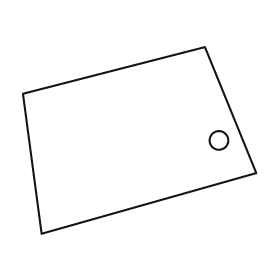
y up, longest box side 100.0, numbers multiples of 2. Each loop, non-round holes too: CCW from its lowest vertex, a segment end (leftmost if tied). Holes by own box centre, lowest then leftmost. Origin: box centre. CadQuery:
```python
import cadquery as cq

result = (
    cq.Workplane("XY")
    .moveTo(-42.0, -40.0)
    .lineTo(50.0, -14.0)
    .lineTo(28.0, 40.0)
    .lineTo(-50.0, 20.0)
    .close()
    .moveTo(34.0, 0.0)
    .circle(4.0)
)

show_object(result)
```